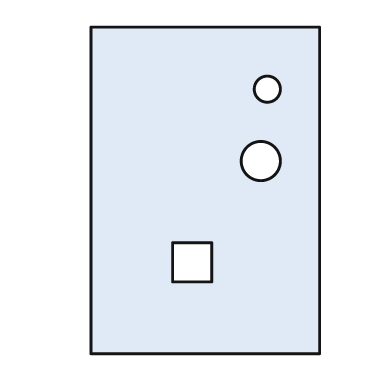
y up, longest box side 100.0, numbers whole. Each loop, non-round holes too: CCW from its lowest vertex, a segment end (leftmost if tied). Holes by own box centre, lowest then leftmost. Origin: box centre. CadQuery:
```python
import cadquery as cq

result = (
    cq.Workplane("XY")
    .moveTo(-35.0, -50.0)
    .lineTo(35.0, -50.0)
    .lineTo(35.0, 50.0)
    .lineTo(-35.0, 50.0)
    .close()
    .moveTo(-10.0, -28.0)
    .lineTo(2.0, -28.0)
    .lineTo(2.0, -16.0)
    .lineTo(-10.0, -16.0)
    .close()
    .moveTo(17.0, 9.0)
    .circle(6.0)
    .moveTo(19.0, 31.0)
    .circle(4.0)
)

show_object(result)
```